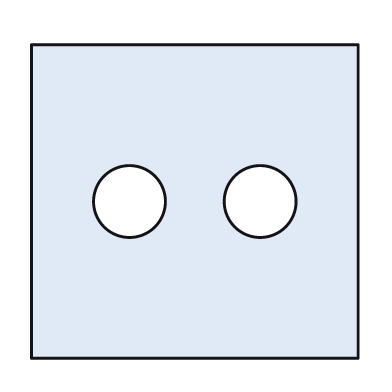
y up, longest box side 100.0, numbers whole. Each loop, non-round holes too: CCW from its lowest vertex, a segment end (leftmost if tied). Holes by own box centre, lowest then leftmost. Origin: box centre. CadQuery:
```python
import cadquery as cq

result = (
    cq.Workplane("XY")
    .moveTo(-50.0, -48.0)
    .lineTo(50.0, -48.0)
    .lineTo(50.0, 48.0)
    .lineTo(-50.0, 48.0)
    .close()
    .moveTo(-20.0, 0.0)
    .circle(11.0)
    .moveTo(20.0, 0.0)
    .circle(11.0)
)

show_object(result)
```